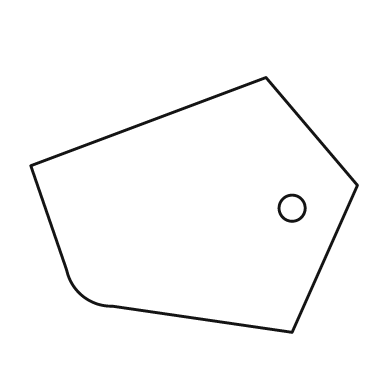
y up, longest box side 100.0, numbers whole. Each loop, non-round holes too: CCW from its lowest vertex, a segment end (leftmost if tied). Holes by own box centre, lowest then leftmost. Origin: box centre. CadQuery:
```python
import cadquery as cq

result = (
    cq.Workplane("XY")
    .moveTo(30.0, -39.0)
    .lineTo(50.0, 6.0)
    .lineTo(22.0, 39.0)
    .lineTo(-50.0, 12.0)
    .lineTo(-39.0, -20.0)
    .threePointArc((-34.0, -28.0), (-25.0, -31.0))
    .close()
    .moveTo(30.0, -1.0)
    .circle(4.0)
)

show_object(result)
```